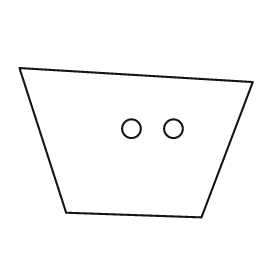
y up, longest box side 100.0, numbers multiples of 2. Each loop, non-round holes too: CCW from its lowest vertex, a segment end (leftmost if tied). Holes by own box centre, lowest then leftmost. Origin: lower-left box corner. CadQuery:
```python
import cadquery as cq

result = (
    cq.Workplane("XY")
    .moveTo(78.0, 0.0)
    .lineTo(100.0, 58.0)
    .lineTo(0.0, 64.0)
    .lineTo(20.0, 2.0)
    .close()
    .moveTo(48.0, 38.0)
    .circle(4.0)
    .moveTo(66.0, 38.0)
    .circle(4.0)
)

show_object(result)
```